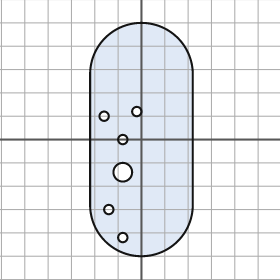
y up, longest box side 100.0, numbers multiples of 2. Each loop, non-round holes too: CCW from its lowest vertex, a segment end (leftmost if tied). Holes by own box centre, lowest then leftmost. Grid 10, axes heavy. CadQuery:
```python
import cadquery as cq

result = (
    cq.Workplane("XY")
    .moveTo(-22.0, -28.0)
    .threePointArc((0.0, -50.0), (22.0, -28.0))
    .lineTo(22.0, 28.0)
    .threePointArc((0.0, 50.0), (-22.0, 28.0))
    .close()
    .moveTo(-8.0, -42.0)
    .circle(2.0)
    .moveTo(-14.0, -30.0)
    .circle(2.0)
    .moveTo(-8.0, -14.0)
    .circle(4.0)
    .moveTo(-8.0, 0.0)
    .circle(2.0)
    .moveTo(-16.0, 10.0)
    .circle(2.0)
    .moveTo(-2.0, 12.0)
    .circle(2.0)
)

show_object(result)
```